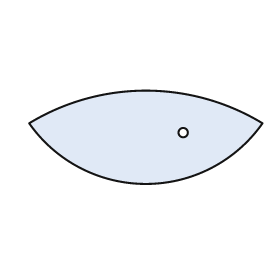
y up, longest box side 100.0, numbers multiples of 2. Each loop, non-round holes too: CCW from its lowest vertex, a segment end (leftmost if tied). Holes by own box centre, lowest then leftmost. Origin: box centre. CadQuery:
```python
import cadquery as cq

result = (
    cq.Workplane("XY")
    .moveTo(-50.0, 6.0)
    .threePointArc((0.0, -20.0), (50.0, 6.0))
    .threePointArc((0.0, 20.0), (-50.0, 6.0))
    .close()
    .moveTo(16.0, 2.0)
    .circle(2.0)
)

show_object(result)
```